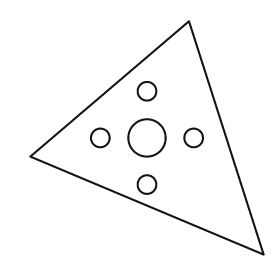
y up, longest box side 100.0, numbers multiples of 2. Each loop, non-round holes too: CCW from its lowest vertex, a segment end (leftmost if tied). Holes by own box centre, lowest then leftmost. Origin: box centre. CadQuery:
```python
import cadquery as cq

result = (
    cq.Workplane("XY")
    .moveTo(50.0, -50.0)
    .lineTo(18.0, 50.0)
    .lineTo(-50.0, -8.0)
    .close()
    .moveTo(0.0, -20.0)
    .circle(4.0)
    .moveTo(-20.0, 0.0)
    .circle(4.0)
    .moveTo(0.0, 0.0)
    .circle(8.0)
    .moveTo(20.0, 0.0)
    .circle(4.0)
    .moveTo(0.0, 20.0)
    .circle(4.0)
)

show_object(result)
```